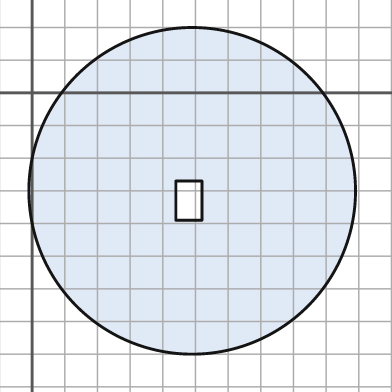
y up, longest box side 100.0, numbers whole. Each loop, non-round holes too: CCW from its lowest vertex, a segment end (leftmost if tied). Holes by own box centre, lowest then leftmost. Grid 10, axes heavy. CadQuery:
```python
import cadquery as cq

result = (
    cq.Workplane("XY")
    .moveTo(49.0, -30.0)
    .circle(50.0)
    .moveTo(44.0, -39.0)
    .lineTo(52.0, -39.0)
    .lineTo(52.0, -27.0)
    .lineTo(44.0, -27.0)
    .close()
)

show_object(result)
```